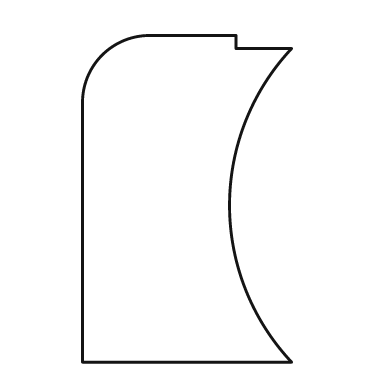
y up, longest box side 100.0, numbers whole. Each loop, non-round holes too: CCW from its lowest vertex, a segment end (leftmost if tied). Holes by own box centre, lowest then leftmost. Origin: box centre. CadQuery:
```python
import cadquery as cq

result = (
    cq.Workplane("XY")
    .moveTo(-32.0, -50.0)
    .lineTo(32.0, -50.0)
    .threePointArc((13.0, -2.0), (32.0, 46.0))
    .lineTo(15.0, 46.0)
    .lineTo(15.0, 50.0)
    .lineTo(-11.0, 50.0)
    .threePointArc((-26.0, 44.0), (-32.0, 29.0))
    .close()
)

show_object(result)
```